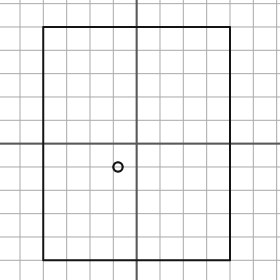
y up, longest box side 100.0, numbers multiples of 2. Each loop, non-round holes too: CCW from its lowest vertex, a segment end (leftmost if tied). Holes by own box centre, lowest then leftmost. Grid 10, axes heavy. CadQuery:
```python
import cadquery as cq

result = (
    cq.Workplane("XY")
    .moveTo(-40.0, -50.0)
    .lineTo(40.0, -50.0)
    .lineTo(40.0, 50.0)
    .lineTo(-40.0, 50.0)
    .close()
    .moveTo(-8.0, -10.0)
    .circle(2.0)
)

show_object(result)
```